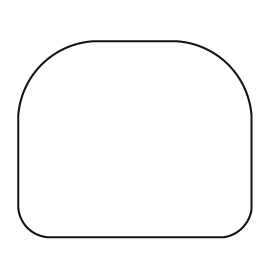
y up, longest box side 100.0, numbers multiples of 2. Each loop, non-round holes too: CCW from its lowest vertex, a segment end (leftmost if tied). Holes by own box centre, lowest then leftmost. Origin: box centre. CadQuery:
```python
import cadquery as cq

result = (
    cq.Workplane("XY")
    .moveTo(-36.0, -42.0)
    .lineTo(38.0, -42.0)
    .threePointArc((46.0, -38.0), (50.0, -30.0))
    .lineTo(50.0, 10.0)
    .threePointArc((40.0, 32.0), (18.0, 42.0))
    .lineTo(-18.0, 42.0)
    .threePointArc((-40.0, 32.0), (-50.0, 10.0))
    .lineTo(-50.0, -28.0)
    .threePointArc((-46.0, -38.0), (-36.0, -42.0))
    .close()
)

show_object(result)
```